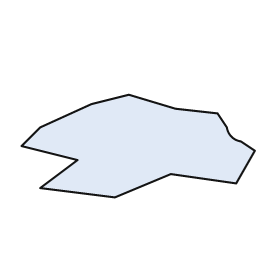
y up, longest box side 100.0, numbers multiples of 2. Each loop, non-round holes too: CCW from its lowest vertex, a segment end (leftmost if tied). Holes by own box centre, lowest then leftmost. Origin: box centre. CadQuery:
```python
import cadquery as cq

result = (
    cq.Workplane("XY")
    .moveTo(-10.0, -22.0)
    .lineTo(14.0, -12.0)
    .lineTo(42.0, -16.0)
    .lineTo(50.0, -2.0)
    .lineTo(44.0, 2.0)
    .threePointArc((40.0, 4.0), (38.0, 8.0))
    .lineTo(34.0, 14.0)
    .lineTo(16.0, 16.0)
    .lineTo(-4.0, 22.0)
    .lineTo(-20.0, 18.0)
    .lineTo(-42.0, 8.0)
    .lineTo(-50.0, 0.0)
    .lineTo(-26.0, -6.0)
    .lineTo(-42.0, -18.0)
    .close()
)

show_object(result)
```